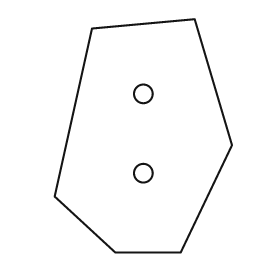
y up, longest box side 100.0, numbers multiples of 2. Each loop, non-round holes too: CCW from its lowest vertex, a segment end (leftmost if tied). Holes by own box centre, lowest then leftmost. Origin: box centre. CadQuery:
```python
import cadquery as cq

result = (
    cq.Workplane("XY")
    .moveTo(-12.0, -50.0)
    .lineTo(16.0, -50.0)
    .lineTo(38.0, -4.0)
    .lineTo(22.0, 50.0)
    .lineTo(-22.0, 46.0)
    .lineTo(-38.0, -26.0)
    .close()
    .moveTo(0.0, -16.0)
    .circle(4.0)
    .moveTo(0.0, 18.0)
    .circle(4.0)
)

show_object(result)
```